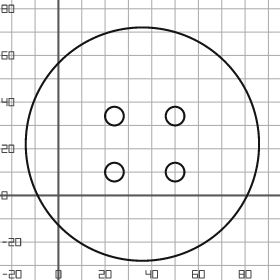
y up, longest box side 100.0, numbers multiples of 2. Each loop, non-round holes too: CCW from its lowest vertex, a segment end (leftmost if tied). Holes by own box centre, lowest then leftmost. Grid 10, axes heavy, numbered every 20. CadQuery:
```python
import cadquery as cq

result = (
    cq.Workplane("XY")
    .moveTo(36.0, 22.0)
    .circle(50.0)
    .moveTo(24.0, 10.0)
    .circle(4.0)
    .moveTo(50.0, 10.0)
    .circle(4.0)
    .moveTo(24.0, 34.0)
    .circle(4.0)
    .moveTo(50.0, 34.0)
    .circle(4.0)
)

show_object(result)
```